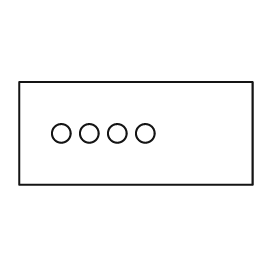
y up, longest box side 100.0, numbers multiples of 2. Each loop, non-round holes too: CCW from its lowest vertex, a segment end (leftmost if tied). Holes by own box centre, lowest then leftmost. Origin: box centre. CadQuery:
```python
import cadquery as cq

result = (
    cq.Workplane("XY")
    .moveTo(-50.0, -22.0)
    .lineTo(50.0, -22.0)
    .lineTo(50.0, 22.0)
    .lineTo(-50.0, 22.0)
    .close()
    .moveTo(-32.0, 0.0)
    .circle(4.0)
    .moveTo(-20.0, 0.0)
    .circle(4.0)
    .moveTo(-8.0, 0.0)
    .circle(4.0)
    .moveTo(4.0, 0.0)
    .circle(4.0)
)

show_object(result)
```